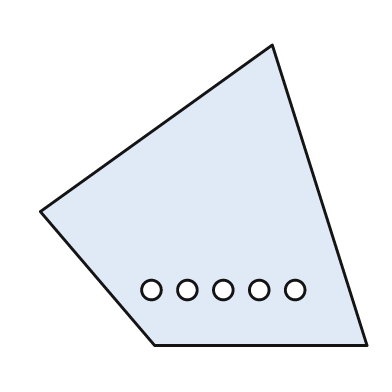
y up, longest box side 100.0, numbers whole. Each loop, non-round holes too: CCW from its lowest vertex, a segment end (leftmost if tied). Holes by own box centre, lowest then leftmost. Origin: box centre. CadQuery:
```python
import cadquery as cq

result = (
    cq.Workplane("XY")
    .moveTo(-15.0, -46.0)
    .lineTo(50.0, -46.0)
    .lineTo(21.0, 46.0)
    .lineTo(-50.0, -5.0)
    .close()
    .moveTo(-16.0, -29.0)
    .circle(3.0)
    .moveTo(-5.0, -29.0)
    .circle(3.0)
    .moveTo(6.0, -29.0)
    .circle(3.0)
    .moveTo(17.0, -29.0)
    .circle(3.0)
    .moveTo(28.0, -29.0)
    .circle(3.0)
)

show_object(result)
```